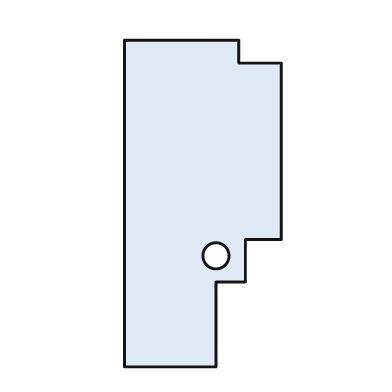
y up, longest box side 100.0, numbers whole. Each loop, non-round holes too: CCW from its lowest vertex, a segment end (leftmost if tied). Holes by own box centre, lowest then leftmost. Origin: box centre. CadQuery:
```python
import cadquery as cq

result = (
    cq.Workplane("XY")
    .moveTo(-24.0, -50.0)
    .lineTo(4.0, -50.0)
    .lineTo(4.0, -24.0)
    .lineTo(13.0, -24.0)
    .lineTo(13.0, -11.0)
    .lineTo(24.0, -11.0)
    .lineTo(24.0, 43.0)
    .lineTo(11.0, 43.0)
    .lineTo(11.0, 50.0)
    .lineTo(-24.0, 50.0)
    .close()
    .moveTo(4.0, -16.0)
    .circle(4.0)
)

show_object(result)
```